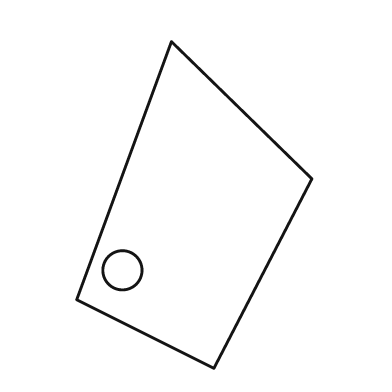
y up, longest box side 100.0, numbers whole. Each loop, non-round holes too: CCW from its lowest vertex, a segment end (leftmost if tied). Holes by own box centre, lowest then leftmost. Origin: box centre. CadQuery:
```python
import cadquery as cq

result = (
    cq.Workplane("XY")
    .moveTo(6.0, -50.0)
    .lineTo(36.0, 8.0)
    .lineTo(-7.0, 50.0)
    .lineTo(-36.0, -29.0)
    .close()
    .moveTo(-22.0, -20.0)
    .circle(6.0)
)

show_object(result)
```